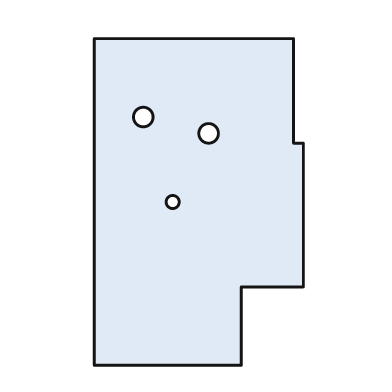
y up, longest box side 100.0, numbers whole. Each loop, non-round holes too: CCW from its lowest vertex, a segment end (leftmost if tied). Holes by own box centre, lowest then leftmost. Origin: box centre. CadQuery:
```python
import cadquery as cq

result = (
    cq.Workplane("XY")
    .moveTo(-32.0, -50.0)
    .lineTo(13.0, -50.0)
    .lineTo(13.0, -26.0)
    .lineTo(32.0, -26.0)
    .lineTo(32.0, 18.0)
    .lineTo(29.0, 18.0)
    .lineTo(29.0, 50.0)
    .lineTo(-32.0, 50.0)
    .close()
    .moveTo(-8.0, 0.0)
    .circle(2.0)
    .moveTo(3.0, 21.0)
    .circle(3.0)
    .moveTo(-17.0, 26.0)
    .circle(3.0)
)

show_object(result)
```